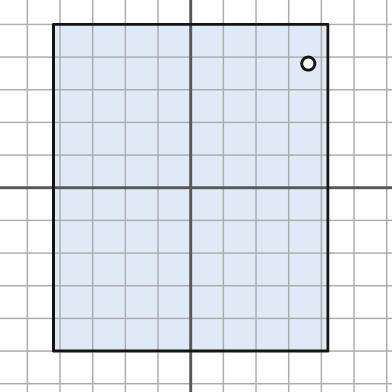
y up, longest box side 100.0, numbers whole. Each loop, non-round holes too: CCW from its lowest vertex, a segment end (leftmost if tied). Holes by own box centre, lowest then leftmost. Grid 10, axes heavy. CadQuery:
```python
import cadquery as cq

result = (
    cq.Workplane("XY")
    .moveTo(-42.0, -50.0)
    .lineTo(42.0, -50.0)
    .lineTo(42.0, 50.0)
    .lineTo(-42.0, 50.0)
    .close()
    .moveTo(36.0, 38.0)
    .circle(2.0)
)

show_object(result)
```